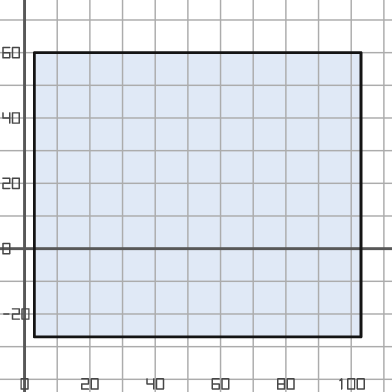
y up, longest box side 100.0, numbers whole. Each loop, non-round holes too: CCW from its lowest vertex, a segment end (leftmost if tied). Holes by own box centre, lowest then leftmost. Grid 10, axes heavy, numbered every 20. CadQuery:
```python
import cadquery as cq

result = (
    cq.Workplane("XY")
    .moveTo(3.0, -27.0)
    .lineTo(103.0, -27.0)
    .lineTo(103.0, 60.0)
    .lineTo(3.0, 60.0)
    .close()
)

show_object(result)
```